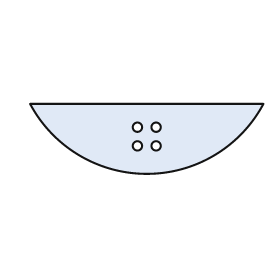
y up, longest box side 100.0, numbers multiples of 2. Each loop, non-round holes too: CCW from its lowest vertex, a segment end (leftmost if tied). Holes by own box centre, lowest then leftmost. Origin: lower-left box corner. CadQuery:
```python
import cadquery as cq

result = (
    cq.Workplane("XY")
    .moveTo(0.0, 30.0)
    .threePointArc((50.0, 0.0), (100.0, 30.0))
    .close()
    .moveTo(46.0, 12.0)
    .circle(2.0)
    .moveTo(54.0, 12.0)
    .circle(2.0)
    .moveTo(46.0, 20.0)
    .circle(2.0)
    .moveTo(54.0, 20.0)
    .circle(2.0)
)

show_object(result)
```